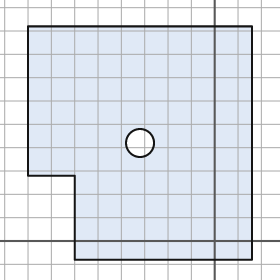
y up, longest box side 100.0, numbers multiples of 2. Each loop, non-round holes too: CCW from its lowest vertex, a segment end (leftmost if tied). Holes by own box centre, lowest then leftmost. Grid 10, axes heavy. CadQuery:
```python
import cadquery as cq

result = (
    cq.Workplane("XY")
    .moveTo(-60.0, -8.0)
    .lineTo(16.0, -8.0)
    .lineTo(16.0, 92.0)
    .lineTo(-80.0, 92.0)
    .lineTo(-80.0, 28.0)
    .lineTo(-60.0, 28.0)
    .close()
    .moveTo(-32.0, 42.0)
    .circle(6.0)
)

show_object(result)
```